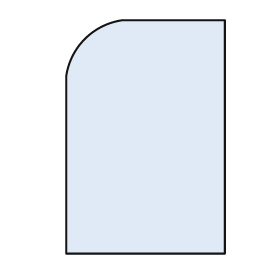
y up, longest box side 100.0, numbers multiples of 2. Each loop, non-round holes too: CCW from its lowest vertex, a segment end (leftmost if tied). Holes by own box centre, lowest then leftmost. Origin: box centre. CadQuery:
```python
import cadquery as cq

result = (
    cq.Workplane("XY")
    .moveTo(-34.0, -50.0)
    .lineTo(34.0, -50.0)
    .lineTo(34.0, 50.0)
    .lineTo(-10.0, 50.0)
    .threePointArc((-26.0, 42.0), (-34.0, 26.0))
    .close()
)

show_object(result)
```